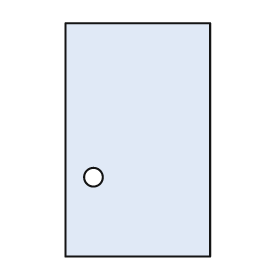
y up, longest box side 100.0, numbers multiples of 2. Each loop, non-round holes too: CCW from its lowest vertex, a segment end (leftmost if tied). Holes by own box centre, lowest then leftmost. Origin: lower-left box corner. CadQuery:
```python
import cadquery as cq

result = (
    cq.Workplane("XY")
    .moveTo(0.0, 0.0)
    .lineTo(62.0, 0.0)
    .lineTo(62.0, 100.0)
    .lineTo(0.0, 100.0)
    .close()
    .moveTo(12.0, 34.0)
    .circle(4.0)
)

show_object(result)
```